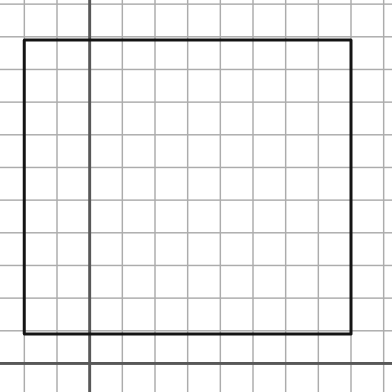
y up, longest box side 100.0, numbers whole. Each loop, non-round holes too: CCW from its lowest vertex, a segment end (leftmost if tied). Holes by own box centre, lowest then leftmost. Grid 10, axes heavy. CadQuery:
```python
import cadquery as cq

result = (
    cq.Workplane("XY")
    .moveTo(-20.0, 9.0)
    .lineTo(80.0, 9.0)
    .lineTo(80.0, 99.0)
    .lineTo(-20.0, 99.0)
    .close()
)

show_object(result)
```